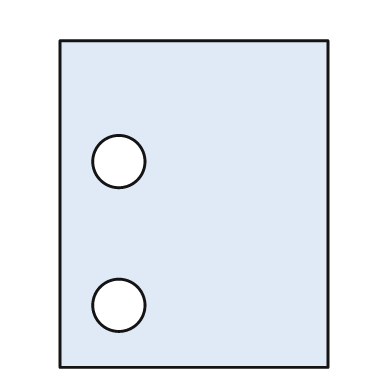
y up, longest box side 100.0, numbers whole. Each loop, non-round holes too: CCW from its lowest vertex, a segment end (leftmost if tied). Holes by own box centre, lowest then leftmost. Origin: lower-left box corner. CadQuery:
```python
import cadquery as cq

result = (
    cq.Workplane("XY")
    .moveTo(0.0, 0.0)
    .lineTo(82.0, 0.0)
    .lineTo(82.0, 100.0)
    .lineTo(0.0, 100.0)
    .close()
    .moveTo(18.0, 19.0)
    .circle(8.0)
    .moveTo(18.0, 63.0)
    .circle(8.0)
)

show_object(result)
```